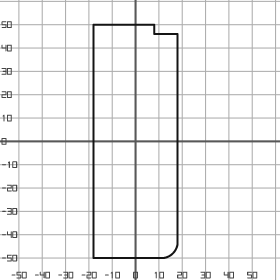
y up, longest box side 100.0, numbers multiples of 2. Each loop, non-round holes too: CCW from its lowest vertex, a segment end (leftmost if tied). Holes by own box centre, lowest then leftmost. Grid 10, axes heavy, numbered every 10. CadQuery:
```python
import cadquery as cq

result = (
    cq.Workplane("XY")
    .moveTo(-18.0, -50.0)
    .lineTo(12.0, -50.0)
    .threePointArc((16.0, -48.0), (18.0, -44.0))
    .lineTo(18.0, 46.0)
    .lineTo(8.0, 46.0)
    .lineTo(8.0, 50.0)
    .lineTo(-18.0, 50.0)
    .close()
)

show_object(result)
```